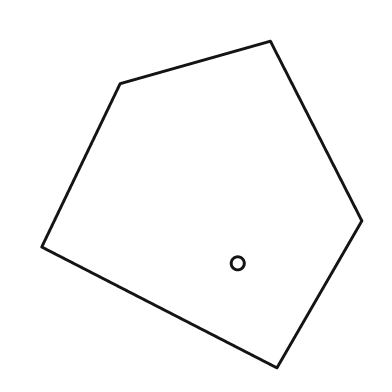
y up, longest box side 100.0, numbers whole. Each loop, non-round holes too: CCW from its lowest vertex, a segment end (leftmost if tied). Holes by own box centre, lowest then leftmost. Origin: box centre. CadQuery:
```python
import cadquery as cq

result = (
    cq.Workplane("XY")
    .moveTo(23.0, -50.0)
    .lineTo(49.0, -5.0)
    .lineTo(21.0, 50.0)
    .lineTo(-25.0, 37.0)
    .lineTo(-49.0, -13.0)
    .close()
    .moveTo(11.0, -18.0)
    .circle(2.0)
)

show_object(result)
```